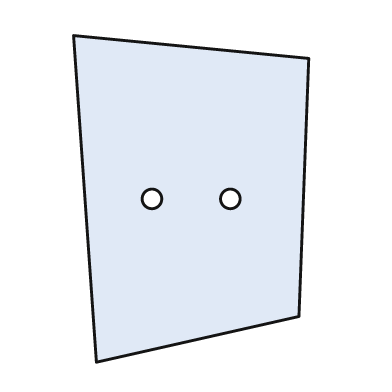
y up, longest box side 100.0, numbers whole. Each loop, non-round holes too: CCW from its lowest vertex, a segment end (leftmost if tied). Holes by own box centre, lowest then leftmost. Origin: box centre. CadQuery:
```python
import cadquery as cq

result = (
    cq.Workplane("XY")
    .moveTo(-29.0, -50.0)
    .lineTo(33.0, -36.0)
    .lineTo(36.0, 43.0)
    .lineTo(-36.0, 50.0)
    .close()
    .moveTo(-12.0, 0.0)
    .circle(3.0)
    .moveTo(12.0, 0.0)
    .circle(3.0)
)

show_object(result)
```